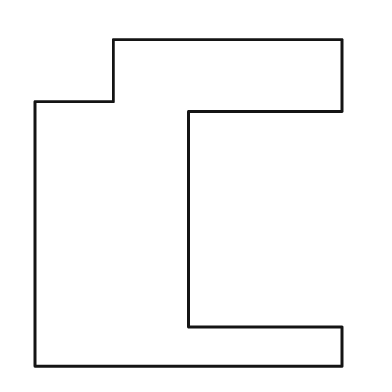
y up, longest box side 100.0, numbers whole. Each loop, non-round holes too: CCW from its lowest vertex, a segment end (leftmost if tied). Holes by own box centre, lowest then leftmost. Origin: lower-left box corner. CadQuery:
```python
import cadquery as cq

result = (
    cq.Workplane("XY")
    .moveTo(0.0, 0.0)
    .lineTo(94.0, 0.0)
    .lineTo(94.0, 12.0)
    .lineTo(47.0, 12.0)
    .lineTo(47.0, 78.0)
    .lineTo(94.0, 78.0)
    .lineTo(94.0, 100.0)
    .lineTo(24.0, 100.0)
    .lineTo(24.0, 81.0)
    .lineTo(0.0, 81.0)
    .close()
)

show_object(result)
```